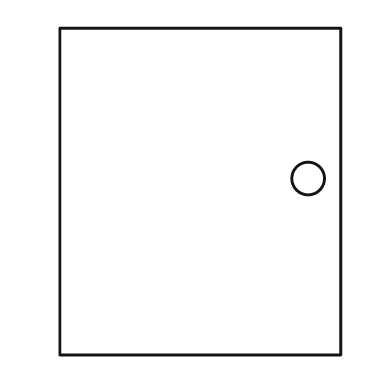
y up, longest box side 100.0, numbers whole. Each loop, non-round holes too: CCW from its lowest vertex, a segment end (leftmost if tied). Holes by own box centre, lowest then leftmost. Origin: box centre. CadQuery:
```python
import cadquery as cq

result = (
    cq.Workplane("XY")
    .moveTo(-43.0, -50.0)
    .lineTo(43.0, -50.0)
    .lineTo(43.0, 50.0)
    .lineTo(-43.0, 50.0)
    .close()
    .moveTo(33.0, 4.0)
    .circle(5.0)
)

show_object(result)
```